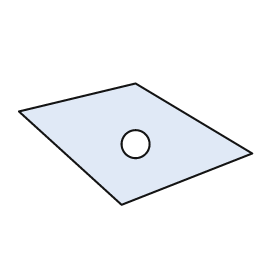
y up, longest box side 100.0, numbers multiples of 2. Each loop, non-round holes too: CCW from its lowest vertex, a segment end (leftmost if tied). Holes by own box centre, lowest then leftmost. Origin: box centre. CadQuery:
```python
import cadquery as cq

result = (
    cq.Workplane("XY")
    .moveTo(-6.0, -26.0)
    .lineTo(50.0, -4.0)
    .lineTo(0.0, 26.0)
    .lineTo(-50.0, 14.0)
    .close()
    .moveTo(0.0, 0.0)
    .circle(6.0)
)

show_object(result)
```